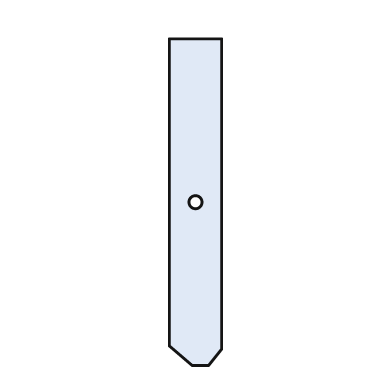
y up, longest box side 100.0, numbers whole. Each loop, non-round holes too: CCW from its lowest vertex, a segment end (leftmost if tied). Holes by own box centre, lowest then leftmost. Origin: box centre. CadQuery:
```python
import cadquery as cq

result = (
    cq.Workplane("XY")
    .moveTo(-1.0, -50.0)
    .lineTo(4.0, -50.0)
    .lineTo(8.0, -45.0)
    .lineTo(8.0, 50.0)
    .lineTo(-8.0, 50.0)
    .lineTo(-8.0, -44.0)
    .close()
    .moveTo(0.0, 0.0)
    .circle(2.0)
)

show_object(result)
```